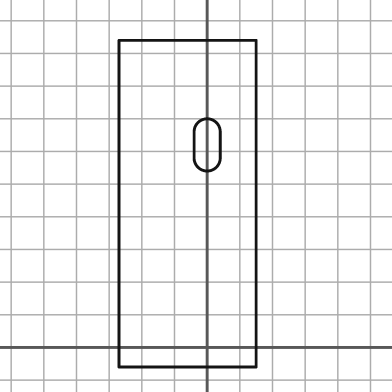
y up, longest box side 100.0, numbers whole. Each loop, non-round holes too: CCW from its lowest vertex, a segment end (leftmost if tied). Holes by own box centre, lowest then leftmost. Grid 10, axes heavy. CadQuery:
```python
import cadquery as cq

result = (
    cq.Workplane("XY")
    .moveTo(-27.0, -6.0)
    .lineTo(15.0, -6.0)
    .lineTo(15.0, 94.0)
    .lineTo(-27.0, 94.0)
    .close()
    .moveTo(-4.0, 58.0)
    .threePointArc((0.0, 54.0), (4.0, 58.0))
    .lineTo(4.0, 66.0)
    .threePointArc((0.0, 70.0), (-4.0, 66.0))
    .close()
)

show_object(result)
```